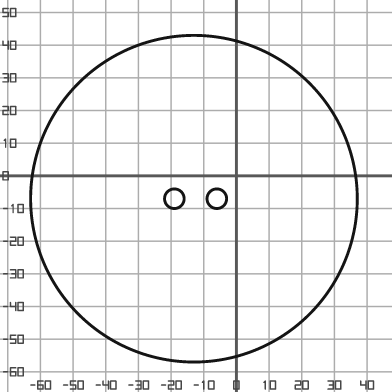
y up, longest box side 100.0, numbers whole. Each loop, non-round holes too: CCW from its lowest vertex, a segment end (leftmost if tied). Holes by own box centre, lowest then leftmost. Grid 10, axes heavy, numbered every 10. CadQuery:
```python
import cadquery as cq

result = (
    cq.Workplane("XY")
    .moveTo(-13.0, -7.0)
    .circle(50.0)
    .moveTo(-19.0, -7.0)
    .circle(3.0)
    .moveTo(-6.0, -7.0)
    .circle(3.0)
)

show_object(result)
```